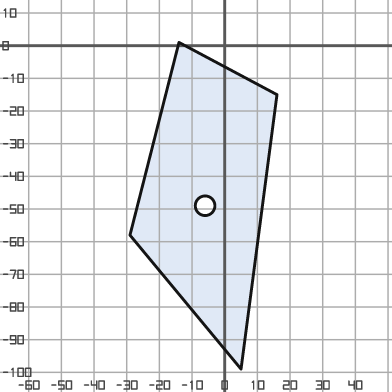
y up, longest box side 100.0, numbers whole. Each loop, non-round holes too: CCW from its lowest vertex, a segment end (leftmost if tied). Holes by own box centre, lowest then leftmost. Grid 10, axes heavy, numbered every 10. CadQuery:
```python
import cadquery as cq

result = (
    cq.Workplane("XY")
    .moveTo(5.0, -99.0)
    .lineTo(16.0, -15.0)
    .lineTo(-14.0, 1.0)
    .lineTo(-29.0, -58.0)
    .close()
    .moveTo(-6.0, -49.0)
    .circle(3.0)
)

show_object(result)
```